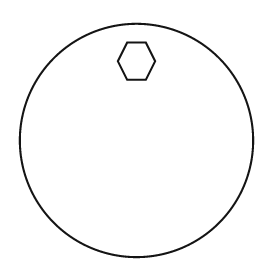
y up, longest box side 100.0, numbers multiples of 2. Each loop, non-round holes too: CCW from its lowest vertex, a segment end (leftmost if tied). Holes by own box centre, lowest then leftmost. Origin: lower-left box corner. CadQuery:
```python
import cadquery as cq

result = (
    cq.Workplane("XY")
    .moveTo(50.0, 50.0)
    .circle(50.0)
    .moveTo(46.0, 76.0)
    .lineTo(54.0, 76.0)
    .lineTo(58.0, 84.0)
    .lineTo(54.0, 92.0)
    .lineTo(46.0, 92.0)
    .lineTo(42.0, 84.0)
    .close()
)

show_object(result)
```